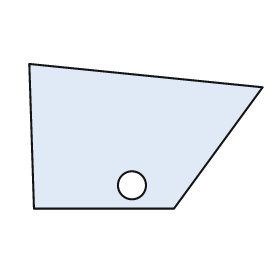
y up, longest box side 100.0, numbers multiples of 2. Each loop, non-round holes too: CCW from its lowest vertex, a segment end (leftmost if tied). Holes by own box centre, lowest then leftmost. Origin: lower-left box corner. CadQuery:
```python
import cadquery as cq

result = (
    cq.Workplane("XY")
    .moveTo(2.0, 0.0)
    .lineTo(62.0, 0.0)
    .lineTo(100.0, 52.0)
    .lineTo(0.0, 62.0)
    .close()
    .moveTo(44.0, 10.0)
    .circle(6.0)
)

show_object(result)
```